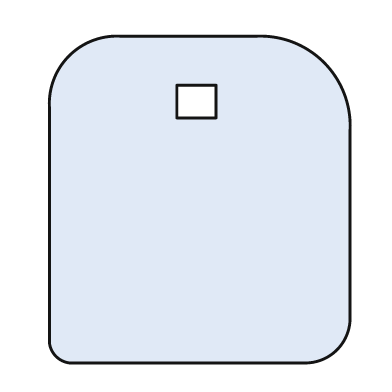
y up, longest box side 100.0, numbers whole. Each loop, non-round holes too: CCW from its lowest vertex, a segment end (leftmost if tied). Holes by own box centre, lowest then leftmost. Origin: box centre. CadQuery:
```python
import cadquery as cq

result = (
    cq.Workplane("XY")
    .moveTo(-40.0, -50.0)
    .lineTo(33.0, -50.0)
    .threePointArc((42.0, -46.0), (46.0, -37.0))
    .lineTo(46.0, 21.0)
    .threePointArc((38.0, 42.0), (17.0, 50.0))
    .lineTo(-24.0, 50.0)
    .threePointArc((-40.0, 44.0), (-46.0, 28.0))
    .lineTo(-46.0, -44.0)
    .threePointArc((-44.0, -48.0), (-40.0, -50.0))
    .close()
    .moveTo(-7.0, 25.0)
    .lineTo(5.0, 25.0)
    .lineTo(5.0, 35.0)
    .lineTo(-7.0, 35.0)
    .close()
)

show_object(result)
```